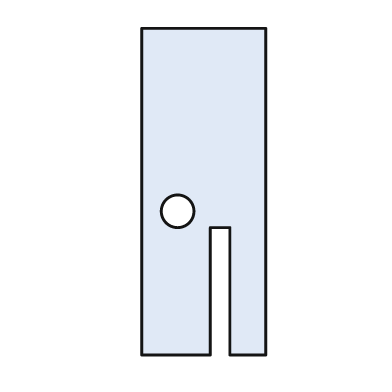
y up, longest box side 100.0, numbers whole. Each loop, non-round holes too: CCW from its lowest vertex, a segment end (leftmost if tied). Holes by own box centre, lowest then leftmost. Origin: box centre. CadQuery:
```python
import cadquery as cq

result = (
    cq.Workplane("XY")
    .moveTo(-19.0, -50.0)
    .lineTo(2.0, -50.0)
    .lineTo(2.0, -11.0)
    .lineTo(8.0, -11.0)
    .lineTo(8.0, -50.0)
    .lineTo(19.0, -50.0)
    .lineTo(19.0, 50.0)
    .lineTo(-19.0, 50.0)
    .close()
    .moveTo(-8.0, -6.0)
    .circle(5.0)
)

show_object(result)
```